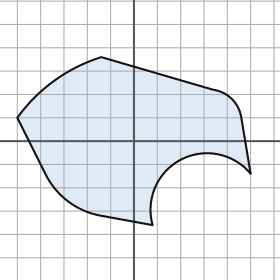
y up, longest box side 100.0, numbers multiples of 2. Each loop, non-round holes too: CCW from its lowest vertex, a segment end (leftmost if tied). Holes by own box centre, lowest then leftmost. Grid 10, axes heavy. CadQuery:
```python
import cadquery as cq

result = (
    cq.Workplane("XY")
    .moveTo(8.0, -36.0)
    .threePointArc((20.0, -8.0), (50.0, -14.0))
    .lineTo(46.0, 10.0)
    .threePointArc((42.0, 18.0), (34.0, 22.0))
    .lineTo(-14.0, 36.0)
    .threePointArc((-34.0, 26.0), (-50.0, 10.0))
    .lineTo(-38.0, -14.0)
    .threePointArc((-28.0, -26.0), (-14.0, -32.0))
    .close()
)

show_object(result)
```